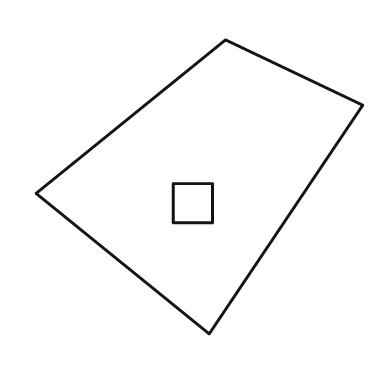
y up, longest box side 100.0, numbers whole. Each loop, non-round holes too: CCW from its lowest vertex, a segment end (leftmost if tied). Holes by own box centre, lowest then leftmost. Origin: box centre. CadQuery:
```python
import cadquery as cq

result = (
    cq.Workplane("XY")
    .moveTo(3.0, -45.0)
    .lineTo(50.0, 25.0)
    .lineTo(8.0, 45.0)
    .lineTo(-50.0, -2.0)
    .close()
    .moveTo(-8.0, -11.0)
    .lineTo(4.0, -11.0)
    .lineTo(4.0, 1.0)
    .lineTo(-8.0, 1.0)
    .close()
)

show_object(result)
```